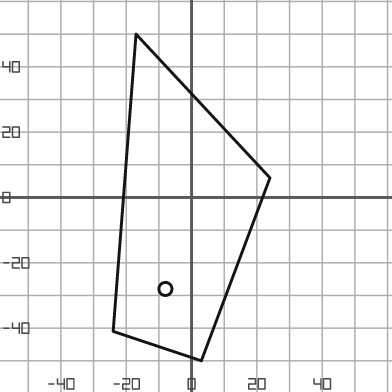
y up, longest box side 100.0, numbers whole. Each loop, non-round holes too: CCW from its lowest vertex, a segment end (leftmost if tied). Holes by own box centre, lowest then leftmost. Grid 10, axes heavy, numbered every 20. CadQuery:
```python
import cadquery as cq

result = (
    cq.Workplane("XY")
    .moveTo(3.0, -50.0)
    .lineTo(24.0, 6.0)
    .lineTo(-17.0, 50.0)
    .lineTo(-24.0, -41.0)
    .close()
    .moveTo(-8.0, -28.0)
    .circle(2.0)
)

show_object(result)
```